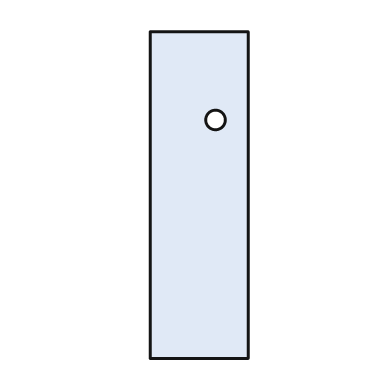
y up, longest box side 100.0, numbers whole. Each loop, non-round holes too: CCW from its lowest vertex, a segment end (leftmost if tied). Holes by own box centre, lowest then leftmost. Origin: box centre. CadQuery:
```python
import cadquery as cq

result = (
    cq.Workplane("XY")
    .moveTo(-15.0, -50.0)
    .lineTo(15.0, -50.0)
    .lineTo(15.0, 50.0)
    .lineTo(-15.0, 50.0)
    .close()
    .moveTo(5.0, 23.0)
    .circle(3.0)
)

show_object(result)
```